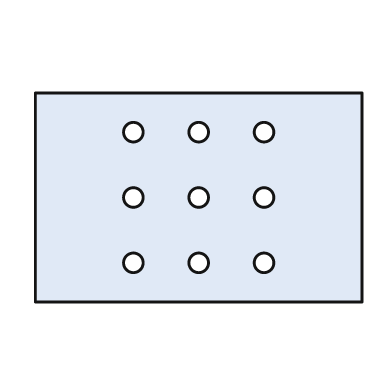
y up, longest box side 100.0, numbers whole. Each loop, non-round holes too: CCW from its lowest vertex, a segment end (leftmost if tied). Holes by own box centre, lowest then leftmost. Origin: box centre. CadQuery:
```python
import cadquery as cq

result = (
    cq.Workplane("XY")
    .moveTo(-50.0, -32.0)
    .lineTo(50.0, -32.0)
    .lineTo(50.0, 32.0)
    .lineTo(-50.0, 32.0)
    .close()
    .moveTo(-20.0, -20.0)
    .circle(3.0)
    .moveTo(0.0, -20.0)
    .circle(3.0)
    .moveTo(20.0, -20.0)
    .circle(3.0)
    .moveTo(-20.0, 0.0)
    .circle(3.0)
    .moveTo(0.0, 0.0)
    .circle(3.0)
    .moveTo(20.0, 0.0)
    .circle(3.0)
    .moveTo(-20.0, 20.0)
    .circle(3.0)
    .moveTo(0.0, 20.0)
    .circle(3.0)
    .moveTo(20.0, 20.0)
    .circle(3.0)
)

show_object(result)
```